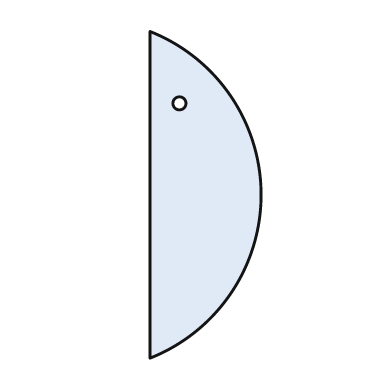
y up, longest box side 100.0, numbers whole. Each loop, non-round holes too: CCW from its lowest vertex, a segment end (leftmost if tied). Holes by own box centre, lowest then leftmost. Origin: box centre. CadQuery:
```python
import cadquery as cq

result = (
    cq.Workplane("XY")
    .moveTo(-17.0, -50.0)
    .threePointArc((17.0, 0.0), (-17.0, 50.0))
    .close()
    .moveTo(-8.0, 28.0)
    .circle(2.0)
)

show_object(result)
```